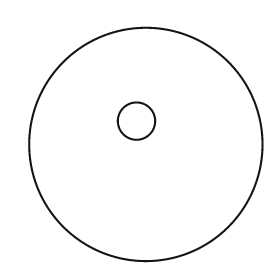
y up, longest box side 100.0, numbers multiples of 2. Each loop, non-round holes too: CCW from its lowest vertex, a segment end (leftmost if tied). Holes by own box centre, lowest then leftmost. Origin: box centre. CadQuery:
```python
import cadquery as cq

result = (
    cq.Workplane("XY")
    .moveTo(0.0, 0.0)
    .circle(50.0)
    .moveTo(-4.0, 10.0)
    .circle(8.0)
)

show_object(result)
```